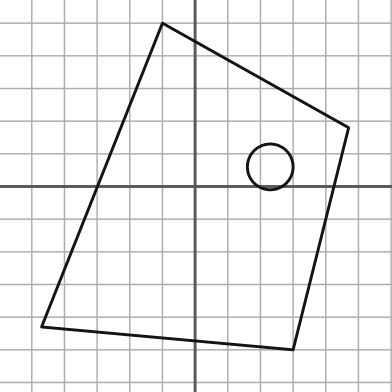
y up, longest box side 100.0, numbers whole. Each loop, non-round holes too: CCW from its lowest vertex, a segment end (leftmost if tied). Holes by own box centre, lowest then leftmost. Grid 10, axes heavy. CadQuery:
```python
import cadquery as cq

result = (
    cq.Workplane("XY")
    .moveTo(30.0, -50.0)
    .lineTo(47.0, 18.0)
    .lineTo(-10.0, 50.0)
    .lineTo(-47.0, -43.0)
    .close()
    .moveTo(23.0, 6.0)
    .circle(7.0)
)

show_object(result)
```